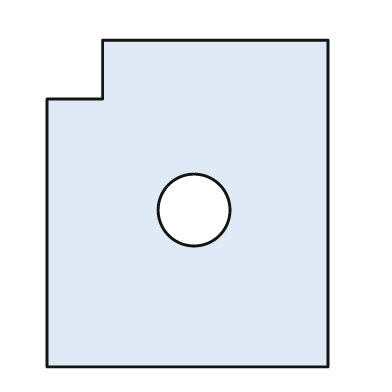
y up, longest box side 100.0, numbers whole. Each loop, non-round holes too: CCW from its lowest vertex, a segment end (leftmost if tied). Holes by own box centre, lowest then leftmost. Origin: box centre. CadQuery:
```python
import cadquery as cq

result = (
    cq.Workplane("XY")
    .moveTo(-43.0, -50.0)
    .lineTo(43.0, -50.0)
    .lineTo(43.0, 50.0)
    .lineTo(-26.0, 50.0)
    .lineTo(-26.0, 32.0)
    .lineTo(-43.0, 32.0)
    .close()
    .moveTo(2.0, -2.0)
    .circle(11.0)
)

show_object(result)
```